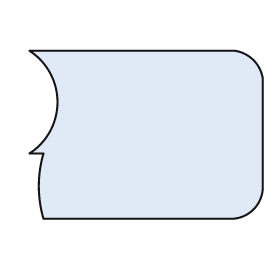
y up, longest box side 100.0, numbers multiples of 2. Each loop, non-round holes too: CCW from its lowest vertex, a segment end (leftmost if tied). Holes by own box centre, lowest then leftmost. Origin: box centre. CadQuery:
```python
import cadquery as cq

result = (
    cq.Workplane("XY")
    .moveTo(-44.0, -36.0)
    .lineTo(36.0, -36.0)
    .threePointArc((46.0, -32.0), (50.0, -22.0))
    .lineTo(50.0, 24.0)
    .threePointArc((46.0, 32.0), (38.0, 36.0))
    .lineTo(-50.0, 36.0)
    .threePointArc((-38.0, 14.0), (-50.0, -8.0))
    .lineTo(-44.0, -8.0)
    .threePointArc((-46.0, -22.0), (-44.0, -36.0))
    .close()
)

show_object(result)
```